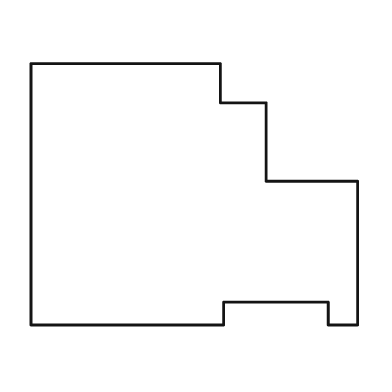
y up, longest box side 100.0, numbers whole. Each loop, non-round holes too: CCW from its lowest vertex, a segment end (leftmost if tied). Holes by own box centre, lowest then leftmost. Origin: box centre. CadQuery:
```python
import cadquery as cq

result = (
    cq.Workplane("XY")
    .moveTo(-50.0, -40.0)
    .lineTo(9.0, -40.0)
    .lineTo(9.0, -33.0)
    .lineTo(41.0, -33.0)
    .lineTo(41.0, -40.0)
    .lineTo(50.0, -40.0)
    .lineTo(50.0, 4.0)
    .lineTo(22.0, 4.0)
    .lineTo(22.0, 28.0)
    .lineTo(8.0, 28.0)
    .lineTo(8.0, 40.0)
    .lineTo(-50.0, 40.0)
    .close()
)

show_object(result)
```